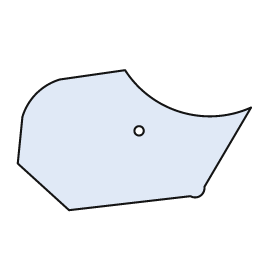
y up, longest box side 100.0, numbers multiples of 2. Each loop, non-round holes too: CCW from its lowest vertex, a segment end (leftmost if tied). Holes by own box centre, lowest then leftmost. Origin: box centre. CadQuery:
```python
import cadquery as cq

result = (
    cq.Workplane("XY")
    .moveTo(-28.0, -30.0)
    .lineTo(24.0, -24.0)
    .threePointArc((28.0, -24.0), (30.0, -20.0))
    .lineTo(50.0, 14.0)
    .threePointArc((20.0, 12.0), (-4.0, 30.0))
    .lineTo(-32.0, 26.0)
    .threePointArc((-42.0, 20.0), (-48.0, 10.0))
    .lineTo(-50.0, -10.0)
    .close()
    .moveTo(2.0, 4.0)
    .circle(2.0)
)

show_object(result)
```